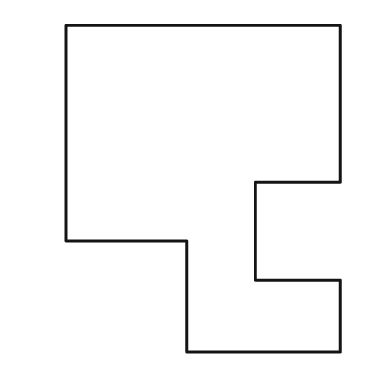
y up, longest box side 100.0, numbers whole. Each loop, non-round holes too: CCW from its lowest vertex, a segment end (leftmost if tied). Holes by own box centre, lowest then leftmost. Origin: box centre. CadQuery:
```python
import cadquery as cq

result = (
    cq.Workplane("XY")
    .moveTo(-5.0, -50.0)
    .lineTo(42.0, -50.0)
    .lineTo(42.0, -28.0)
    .lineTo(16.0, -28.0)
    .lineTo(16.0, 2.0)
    .lineTo(42.0, 2.0)
    .lineTo(42.0, 50.0)
    .lineTo(-42.0, 50.0)
    .lineTo(-42.0, -16.0)
    .lineTo(-5.0, -16.0)
    .close()
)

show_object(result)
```